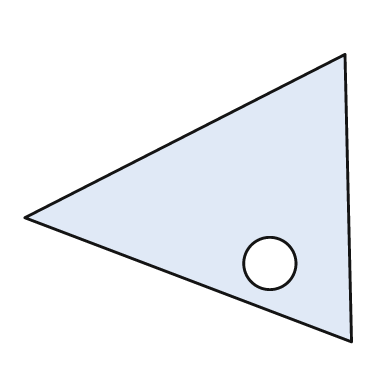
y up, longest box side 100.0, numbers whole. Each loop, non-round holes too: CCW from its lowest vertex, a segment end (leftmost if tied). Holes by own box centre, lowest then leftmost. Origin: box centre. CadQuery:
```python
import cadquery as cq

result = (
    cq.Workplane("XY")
    .moveTo(50.0, -44.0)
    .lineTo(48.0, 44.0)
    .lineTo(-50.0, -6.0)
    .close()
    .moveTo(25.0, -20.0)
    .circle(8.0)
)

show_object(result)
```